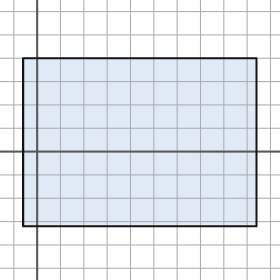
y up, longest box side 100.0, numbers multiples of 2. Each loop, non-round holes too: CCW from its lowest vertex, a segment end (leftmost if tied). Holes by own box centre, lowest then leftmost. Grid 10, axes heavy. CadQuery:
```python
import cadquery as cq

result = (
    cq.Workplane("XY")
    .moveTo(-6.0, -32.0)
    .lineTo(94.0, -32.0)
    .lineTo(94.0, 40.0)
    .lineTo(-6.0, 40.0)
    .close()
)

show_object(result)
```